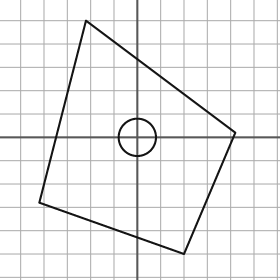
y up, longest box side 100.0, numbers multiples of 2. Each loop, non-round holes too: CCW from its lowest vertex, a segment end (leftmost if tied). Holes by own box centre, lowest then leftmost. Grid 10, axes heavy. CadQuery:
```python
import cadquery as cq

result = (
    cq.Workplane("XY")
    .moveTo(20.0, -50.0)
    .lineTo(42.0, 2.0)
    .lineTo(-22.0, 50.0)
    .lineTo(-42.0, -28.0)
    .close()
    .moveTo(0.0, 0.0)
    .circle(8.0)
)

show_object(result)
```